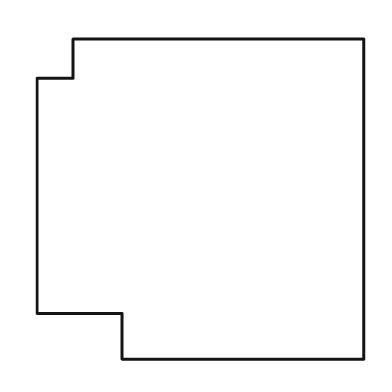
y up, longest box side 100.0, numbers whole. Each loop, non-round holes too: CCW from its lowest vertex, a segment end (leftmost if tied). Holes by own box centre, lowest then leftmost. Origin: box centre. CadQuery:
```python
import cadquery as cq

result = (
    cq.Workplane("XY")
    .moveTo(-24.0, -49.0)
    .lineTo(50.0, -49.0)
    .lineTo(50.0, 49.0)
    .lineTo(-39.0, 49.0)
    .lineTo(-39.0, 37.0)
    .lineTo(-50.0, 37.0)
    .lineTo(-50.0, -35.0)
    .lineTo(-24.0, -35.0)
    .close()
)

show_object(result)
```